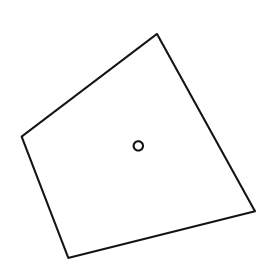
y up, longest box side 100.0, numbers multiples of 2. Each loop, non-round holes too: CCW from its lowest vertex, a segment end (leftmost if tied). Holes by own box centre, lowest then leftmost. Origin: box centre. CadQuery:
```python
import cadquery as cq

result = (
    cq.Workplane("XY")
    .moveTo(-30.0, -48.0)
    .lineTo(50.0, -28.0)
    .lineTo(8.0, 48.0)
    .lineTo(-50.0, 4.0)
    .close()
    .moveTo(0.0, 0.0)
    .circle(2.0)
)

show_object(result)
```